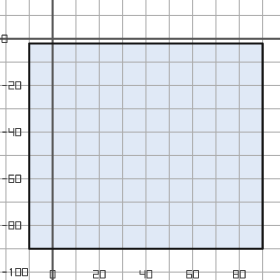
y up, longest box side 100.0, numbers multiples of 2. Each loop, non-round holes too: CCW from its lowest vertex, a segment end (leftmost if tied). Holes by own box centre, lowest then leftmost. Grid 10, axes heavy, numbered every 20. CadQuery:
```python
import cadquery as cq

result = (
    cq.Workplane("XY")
    .moveTo(-10.0, -90.0)
    .lineTo(90.0, -90.0)
    .lineTo(90.0, -2.0)
    .lineTo(-10.0, -2.0)
    .close()
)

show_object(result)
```